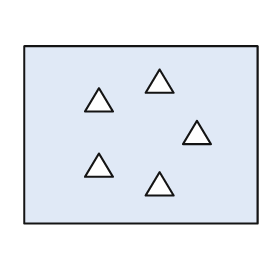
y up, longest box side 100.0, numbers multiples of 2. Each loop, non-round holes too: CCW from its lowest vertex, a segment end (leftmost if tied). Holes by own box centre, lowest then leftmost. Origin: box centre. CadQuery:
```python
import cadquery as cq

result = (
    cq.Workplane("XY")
    .moveTo(-50.0, -38.0)
    .lineTo(50.0, -38.0)
    .lineTo(50.0, 38.0)
    .lineTo(-50.0, 38.0)
    .close()
    .moveTo(2.0, -26.0)
    .lineTo(14.0, -26.0)
    .lineTo(8.0, -16.0)
    .close()
    .moveTo(-24.0, -18.0)
    .lineTo(-12.0, -18.0)
    .lineTo(-18.0, -8.0)
    .close()
    .moveTo(18.0, -4.0)
    .lineTo(30.0, -4.0)
    .lineTo(24.0, 6.0)
    .close()
    .moveTo(-24.0, 10.0)
    .lineTo(-12.0, 10.0)
    .lineTo(-18.0, 20.0)
    .close()
    .moveTo(2.0, 18.0)
    .lineTo(14.0, 18.0)
    .lineTo(8.0, 28.0)
    .close()
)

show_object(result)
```